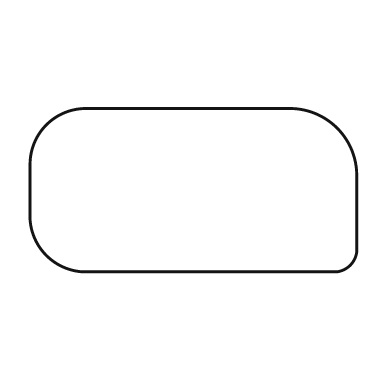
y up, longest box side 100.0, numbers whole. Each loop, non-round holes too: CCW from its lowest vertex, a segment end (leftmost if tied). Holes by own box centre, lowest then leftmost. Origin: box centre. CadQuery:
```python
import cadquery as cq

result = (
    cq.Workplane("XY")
    .moveTo(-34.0, -25.0)
    .lineTo(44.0, -25.0)
    .threePointArc((48.0, -23.0), (50.0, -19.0))
    .lineTo(50.0, 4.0)
    .threePointArc((44.0, 19.0), (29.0, 25.0))
    .lineTo(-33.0, 25.0)
    .threePointArc((-45.0, 20.0), (-50.0, 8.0))
    .lineTo(-50.0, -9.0)
    .threePointArc((-45.0, -20.0), (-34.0, -25.0))
    .close()
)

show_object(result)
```